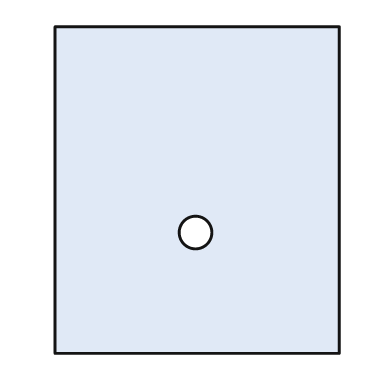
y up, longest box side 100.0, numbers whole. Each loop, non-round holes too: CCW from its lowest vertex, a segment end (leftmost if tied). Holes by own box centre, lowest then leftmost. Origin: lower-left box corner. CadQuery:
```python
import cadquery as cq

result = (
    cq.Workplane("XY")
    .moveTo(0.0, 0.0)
    .lineTo(87.0, 0.0)
    .lineTo(87.0, 100.0)
    .lineTo(0.0, 100.0)
    .close()
    .moveTo(43.0, 37.0)
    .circle(5.0)
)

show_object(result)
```